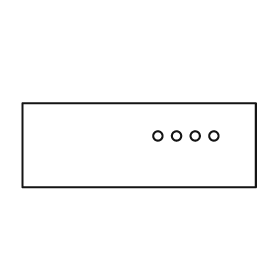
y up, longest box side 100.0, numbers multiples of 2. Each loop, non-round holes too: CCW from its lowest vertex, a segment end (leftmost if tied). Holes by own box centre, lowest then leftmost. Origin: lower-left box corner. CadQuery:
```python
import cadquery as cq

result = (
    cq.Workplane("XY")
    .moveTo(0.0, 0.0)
    .lineTo(100.0, 0.0)
    .lineTo(100.0, 36.0)
    .lineTo(0.0, 36.0)
    .close()
    .moveTo(58.0, 22.0)
    .circle(2.0)
    .moveTo(66.0, 22.0)
    .circle(2.0)
    .moveTo(74.0, 22.0)
    .circle(2.0)
    .moveTo(82.0, 22.0)
    .circle(2.0)
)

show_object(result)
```